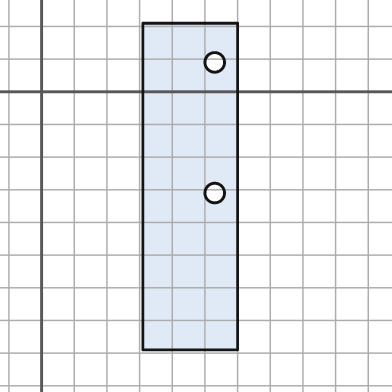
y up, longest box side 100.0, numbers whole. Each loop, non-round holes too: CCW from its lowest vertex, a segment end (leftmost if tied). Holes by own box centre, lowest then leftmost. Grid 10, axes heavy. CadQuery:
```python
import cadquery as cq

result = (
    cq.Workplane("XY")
    .moveTo(31.0, -79.0)
    .lineTo(60.0, -79.0)
    .lineTo(60.0, 21.0)
    .lineTo(31.0, 21.0)
    .close()
    .moveTo(53.0, -31.0)
    .circle(3.0)
    .moveTo(53.0, 9.0)
    .circle(3.0)
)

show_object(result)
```